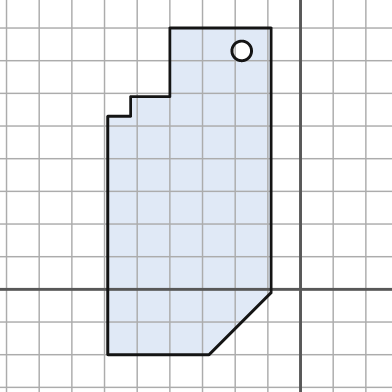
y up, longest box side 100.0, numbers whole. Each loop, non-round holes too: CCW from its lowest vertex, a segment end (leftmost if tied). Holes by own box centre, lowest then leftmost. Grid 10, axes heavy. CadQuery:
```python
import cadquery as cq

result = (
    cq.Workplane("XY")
    .moveTo(-59.0, -20.0)
    .lineTo(-28.0, -20.0)
    .lineTo(-9.0, -1.0)
    .lineTo(-9.0, 80.0)
    .lineTo(-40.0, 80.0)
    .lineTo(-40.0, 59.0)
    .lineTo(-52.0, 59.0)
    .lineTo(-52.0, 53.0)
    .lineTo(-59.0, 53.0)
    .close()
    .moveTo(-18.0, 73.0)
    .circle(3.0)
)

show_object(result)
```